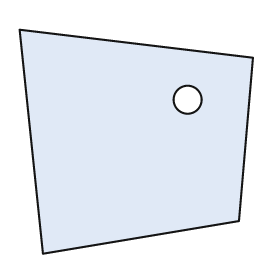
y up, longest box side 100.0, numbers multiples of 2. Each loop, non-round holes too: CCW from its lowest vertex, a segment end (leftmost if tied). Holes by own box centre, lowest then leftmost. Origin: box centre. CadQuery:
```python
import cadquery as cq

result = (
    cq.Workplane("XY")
    .moveTo(-40.0, -48.0)
    .lineTo(44.0, -34.0)
    .lineTo(50.0, 36.0)
    .lineTo(-50.0, 48.0)
    .close()
    .moveTo(22.0, 18.0)
    .circle(6.0)
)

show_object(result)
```